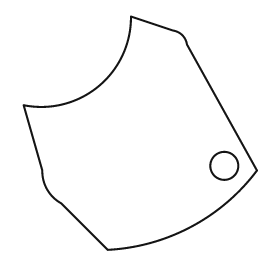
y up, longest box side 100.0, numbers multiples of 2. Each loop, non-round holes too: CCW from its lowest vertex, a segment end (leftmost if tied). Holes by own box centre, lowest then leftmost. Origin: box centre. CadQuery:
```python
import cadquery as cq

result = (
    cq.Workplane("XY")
    .moveTo(-14.0, -50.0)
    .threePointArc((22.0, -40.0), (50.0, -16.0))
    .lineTo(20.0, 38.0)
    .threePointArc((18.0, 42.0), (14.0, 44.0))
    .lineTo(-4.0, 50.0)
    .threePointArc((-18.0, 20.0), (-50.0, 12.0))
    .lineTo(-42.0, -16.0)
    .threePointArc((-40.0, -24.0), (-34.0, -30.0))
    .close()
    .moveTo(36.0, -14.0)
    .circle(6.0)
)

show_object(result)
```